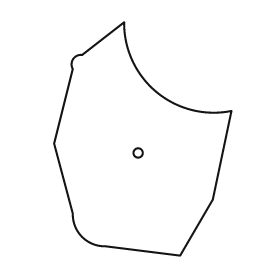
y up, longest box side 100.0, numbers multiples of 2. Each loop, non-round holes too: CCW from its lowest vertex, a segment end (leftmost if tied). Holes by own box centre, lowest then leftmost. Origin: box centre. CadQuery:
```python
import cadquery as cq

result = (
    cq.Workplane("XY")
    .moveTo(16.0, -50.0)
    .lineTo(30.0, -26.0)
    .lineTo(38.0, 12.0)
    .threePointArc((6.0, 20.0), (-8.0, 50.0))
    .lineTo(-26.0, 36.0)
    .threePointArc((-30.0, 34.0), (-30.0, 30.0))
    .lineTo(-38.0, -2.0)
    .lineTo(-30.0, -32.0)
    .threePointArc((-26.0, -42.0), (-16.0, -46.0))
    .close()
    .moveTo(-2.0, -6.0)
    .circle(2.0)
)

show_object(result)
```